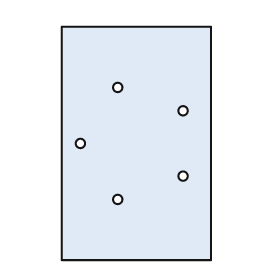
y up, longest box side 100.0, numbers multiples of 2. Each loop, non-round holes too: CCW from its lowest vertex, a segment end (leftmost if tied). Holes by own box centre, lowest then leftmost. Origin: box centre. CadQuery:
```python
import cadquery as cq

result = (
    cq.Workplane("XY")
    .moveTo(-32.0, -50.0)
    .lineTo(32.0, -50.0)
    .lineTo(32.0, 50.0)
    .lineTo(-32.0, 50.0)
    .close()
    .moveTo(-8.0, -24.0)
    .circle(2.0)
    .moveTo(20.0, -14.0)
    .circle(2.0)
    .moveTo(-24.0, 0.0)
    .circle(2.0)
    .moveTo(20.0, 14.0)
    .circle(2.0)
    .moveTo(-8.0, 24.0)
    .circle(2.0)
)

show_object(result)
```